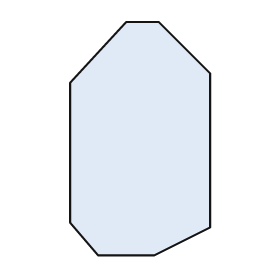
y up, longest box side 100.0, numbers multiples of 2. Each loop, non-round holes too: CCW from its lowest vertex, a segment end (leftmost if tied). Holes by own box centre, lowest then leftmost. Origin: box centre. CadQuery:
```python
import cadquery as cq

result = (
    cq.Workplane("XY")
    .moveTo(-18.0, -50.0)
    .lineTo(6.0, -50.0)
    .lineTo(30.0, -38.0)
    .lineTo(30.0, 28.0)
    .lineTo(8.0, 50.0)
    .lineTo(-6.0, 50.0)
    .lineTo(-30.0, 24.0)
    .lineTo(-30.0, -36.0)
    .close()
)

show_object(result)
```